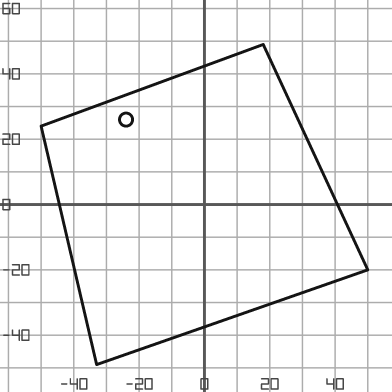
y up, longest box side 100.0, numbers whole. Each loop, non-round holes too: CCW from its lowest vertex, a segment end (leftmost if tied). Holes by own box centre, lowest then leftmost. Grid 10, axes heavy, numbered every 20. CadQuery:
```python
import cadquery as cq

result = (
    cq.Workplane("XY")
    .moveTo(-33.0, -49.0)
    .lineTo(50.0, -20.0)
    .lineTo(18.0, 49.0)
    .lineTo(-50.0, 24.0)
    .close()
    .moveTo(-24.0, 26.0)
    .circle(2.0)
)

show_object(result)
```